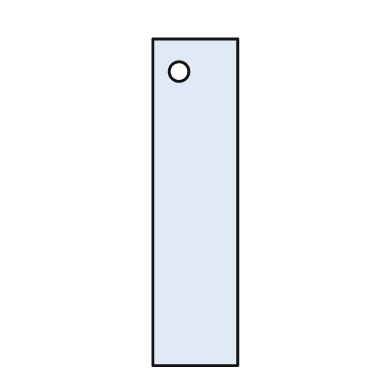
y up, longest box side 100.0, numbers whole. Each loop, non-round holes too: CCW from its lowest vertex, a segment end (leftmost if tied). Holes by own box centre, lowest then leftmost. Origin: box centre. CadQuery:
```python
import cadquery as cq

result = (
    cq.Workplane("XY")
    .moveTo(-13.0, -50.0)
    .lineTo(13.0, -50.0)
    .lineTo(13.0, 50.0)
    .lineTo(-13.0, 50.0)
    .close()
    .moveTo(-5.0, 40.0)
    .circle(3.0)
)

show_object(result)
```